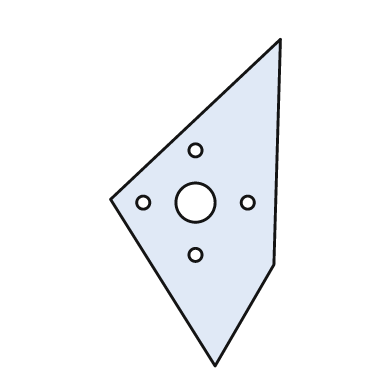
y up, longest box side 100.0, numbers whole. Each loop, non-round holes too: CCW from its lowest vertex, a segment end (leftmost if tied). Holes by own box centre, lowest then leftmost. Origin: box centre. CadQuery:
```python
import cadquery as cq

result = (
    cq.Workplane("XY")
    .moveTo(6.0, -50.0)
    .lineTo(24.0, -19.0)
    .lineTo(26.0, 50.0)
    .lineTo(-26.0, 1.0)
    .close()
    .moveTo(0.0, -16.0)
    .circle(2.0)
    .moveTo(-16.0, 0.0)
    .circle(2.0)
    .moveTo(0.0, 0.0)
    .circle(6.0)
    .moveTo(16.0, 0.0)
    .circle(2.0)
    .moveTo(0.0, 16.0)
    .circle(2.0)
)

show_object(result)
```